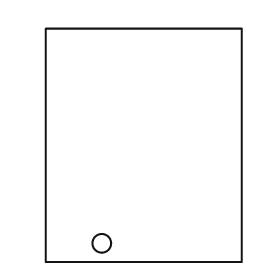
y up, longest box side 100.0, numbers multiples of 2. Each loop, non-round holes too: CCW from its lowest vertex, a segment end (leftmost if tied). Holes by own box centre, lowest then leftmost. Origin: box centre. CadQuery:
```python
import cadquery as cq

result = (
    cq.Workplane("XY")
    .moveTo(-42.0, -50.0)
    .lineTo(42.0, -50.0)
    .lineTo(42.0, 50.0)
    .lineTo(-42.0, 50.0)
    .close()
    .moveTo(-18.0, -42.0)
    .circle(4.0)
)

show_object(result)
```